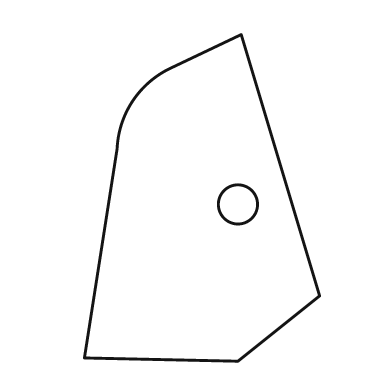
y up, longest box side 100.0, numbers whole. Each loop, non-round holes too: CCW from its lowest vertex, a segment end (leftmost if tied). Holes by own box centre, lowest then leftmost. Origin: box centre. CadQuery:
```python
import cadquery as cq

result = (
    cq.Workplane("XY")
    .moveTo(11.0, -50.0)
    .lineTo(36.0, -30.0)
    .lineTo(12.0, 50.0)
    .lineTo(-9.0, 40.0)
    .threePointArc((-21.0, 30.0), (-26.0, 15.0))
    .lineTo(-36.0, -49.0)
    .close()
    .moveTo(11.0, -2.0)
    .circle(6.0)
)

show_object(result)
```